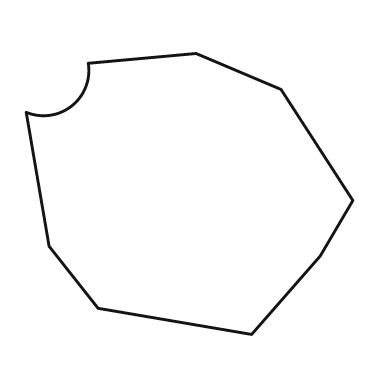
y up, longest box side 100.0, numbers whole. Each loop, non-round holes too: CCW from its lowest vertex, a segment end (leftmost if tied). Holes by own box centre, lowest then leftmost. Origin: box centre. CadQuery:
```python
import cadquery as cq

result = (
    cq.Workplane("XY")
    .moveTo(19.0, -43.0)
    .lineTo(40.0, -19.0)
    .lineTo(50.0, -2.0)
    .lineTo(28.0, 32.0)
    .lineTo(2.0, 43.0)
    .lineTo(-31.0, 40.0)
    .threePointArc((-36.0, 27.0), (-50.0, 25.0))
    .lineTo(-43.0, -16.0)
    .lineTo(-28.0, -35.0)
    .close()
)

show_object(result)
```